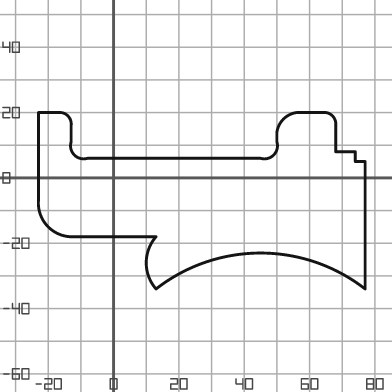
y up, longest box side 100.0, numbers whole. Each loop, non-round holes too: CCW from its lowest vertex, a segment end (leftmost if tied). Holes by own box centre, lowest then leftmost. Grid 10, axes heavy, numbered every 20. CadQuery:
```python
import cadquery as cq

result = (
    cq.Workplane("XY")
    .moveTo(13.0, -34.0)
    .threePointArc((45.0, -23.0), (77.0, -34.0))
    .lineTo(77.0, 5.0)
    .lineTo(74.0, 5.0)
    .lineTo(74.0, 8.0)
    .lineTo(68.0, 8.0)
    .lineTo(68.0, 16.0)
    .threePointArc((67.0, 19.0), (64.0, 20.0))
    .lineTo(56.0, 20.0)
    .threePointArc((52.0, 18.0), (50.0, 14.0))
    .lineTo(50.0, 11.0)
    .threePointArc((49.0, 7.0), (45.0, 6.0))
    .lineTo(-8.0, 6.0)
    .threePointArc((-12.0, 7.0), (-13.0, 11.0))
    .lineTo(-13.0, 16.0)
    .threePointArc((-14.0, 19.0), (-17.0, 20.0))
    .lineTo(-23.0, 20.0)
    .lineTo(-23.0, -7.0)
    .threePointArc((-20.0, -15.0), (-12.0, -18.0))
    .lineTo(13.0, -18.0)
    .threePointArc((10.0, -26.0), (13.0, -34.0))
    .close()
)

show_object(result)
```